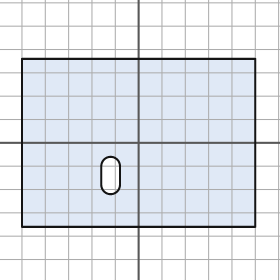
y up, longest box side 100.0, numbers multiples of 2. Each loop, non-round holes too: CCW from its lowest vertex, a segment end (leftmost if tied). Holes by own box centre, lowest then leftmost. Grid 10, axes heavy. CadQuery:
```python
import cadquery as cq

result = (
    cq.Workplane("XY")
    .moveTo(-50.0, -36.0)
    .lineTo(50.0, -36.0)
    .lineTo(50.0, 36.0)
    .lineTo(-50.0, 36.0)
    .close()
    .moveTo(-16.0, -18.0)
    .threePointArc((-12.0, -22.0), (-8.0, -18.0))
    .lineTo(-8.0, -10.0)
    .threePointArc((-12.0, -6.0), (-16.0, -10.0))
    .close()
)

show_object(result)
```